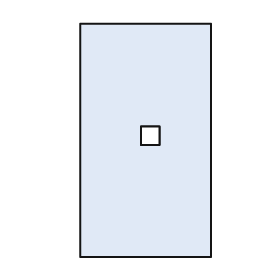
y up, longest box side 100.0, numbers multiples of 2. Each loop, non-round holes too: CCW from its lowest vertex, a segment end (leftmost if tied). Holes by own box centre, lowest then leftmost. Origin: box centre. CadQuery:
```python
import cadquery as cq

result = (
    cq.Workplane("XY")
    .moveTo(-28.0, -50.0)
    .lineTo(28.0, -50.0)
    .lineTo(28.0, 50.0)
    .lineTo(-28.0, 50.0)
    .close()
    .moveTo(-2.0, -2.0)
    .lineTo(6.0, -2.0)
    .lineTo(6.0, 6.0)
    .lineTo(-2.0, 6.0)
    .close()
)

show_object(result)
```